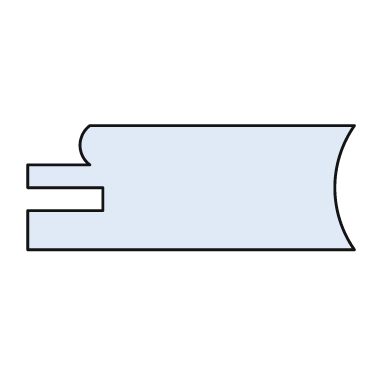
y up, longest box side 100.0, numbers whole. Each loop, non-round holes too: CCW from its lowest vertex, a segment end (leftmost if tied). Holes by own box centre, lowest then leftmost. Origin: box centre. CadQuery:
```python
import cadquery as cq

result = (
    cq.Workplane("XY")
    .moveTo(-50.0, -19.0)
    .lineTo(50.0, -19.0)
    .threePointArc((44.0, 0.0), (50.0, 19.0))
    .lineTo(-31.0, 19.0)
    .threePointArc((-34.0, 13.0), (-31.0, 7.0))
    .lineTo(-50.0, 7.0)
    .lineTo(-50.0, 0.0)
    .lineTo(-27.0, 0.0)
    .lineTo(-27.0, -7.0)
    .lineTo(-50.0, -7.0)
    .close()
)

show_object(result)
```